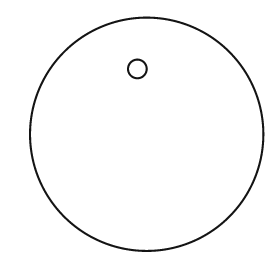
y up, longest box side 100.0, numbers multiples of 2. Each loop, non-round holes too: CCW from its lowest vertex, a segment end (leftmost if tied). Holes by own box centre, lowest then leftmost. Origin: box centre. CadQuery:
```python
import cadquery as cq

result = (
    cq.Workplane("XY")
    .moveTo(0.0, 0.0)
    .circle(50.0)
    .moveTo(-4.0, 28.0)
    .circle(4.0)
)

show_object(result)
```